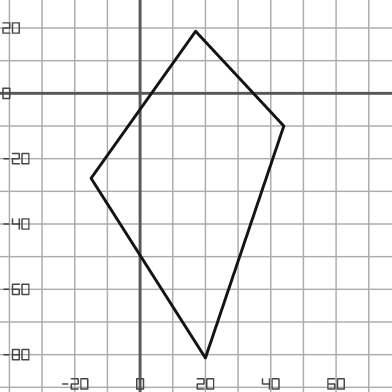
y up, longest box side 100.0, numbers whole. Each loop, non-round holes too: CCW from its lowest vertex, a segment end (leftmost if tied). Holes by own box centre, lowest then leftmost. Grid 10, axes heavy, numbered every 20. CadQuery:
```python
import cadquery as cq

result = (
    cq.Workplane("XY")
    .moveTo(20.0, -81.0)
    .lineTo(44.0, -10.0)
    .lineTo(17.0, 19.0)
    .lineTo(-15.0, -26.0)
    .close()
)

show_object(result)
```